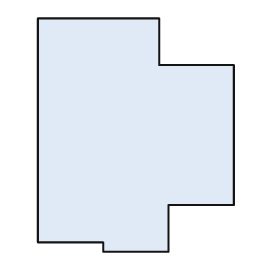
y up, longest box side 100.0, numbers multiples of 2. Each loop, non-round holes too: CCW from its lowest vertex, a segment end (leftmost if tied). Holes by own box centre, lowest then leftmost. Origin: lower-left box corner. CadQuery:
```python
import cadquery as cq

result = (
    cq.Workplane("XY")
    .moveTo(28.0, 0.0)
    .lineTo(56.0, 0.0)
    .lineTo(56.0, 20.0)
    .lineTo(84.0, 20.0)
    .lineTo(84.0, 80.0)
    .lineTo(52.0, 80.0)
    .lineTo(52.0, 100.0)
    .lineTo(0.0, 100.0)
    .lineTo(0.0, 4.0)
    .lineTo(28.0, 4.0)
    .close()
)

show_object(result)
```